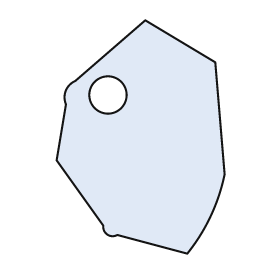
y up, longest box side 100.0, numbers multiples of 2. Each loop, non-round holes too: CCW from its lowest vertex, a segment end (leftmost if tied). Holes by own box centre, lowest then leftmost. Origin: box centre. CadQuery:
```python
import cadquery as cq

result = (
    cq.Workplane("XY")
    .moveTo(20.0, -50.0)
    .threePointArc((30.0, -34.0), (36.0, -16.0))
    .lineTo(32.0, 32.0)
    .lineTo(2.0, 50.0)
    .lineTo(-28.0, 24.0)
    .threePointArc((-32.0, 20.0), (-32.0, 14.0))
    .lineTo(-36.0, -10.0)
    .lineTo(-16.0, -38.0)
    .threePointArc((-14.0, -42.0), (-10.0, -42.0))
    .close()
    .moveTo(-14.0, 18.0)
    .circle(8.0)
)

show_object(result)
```